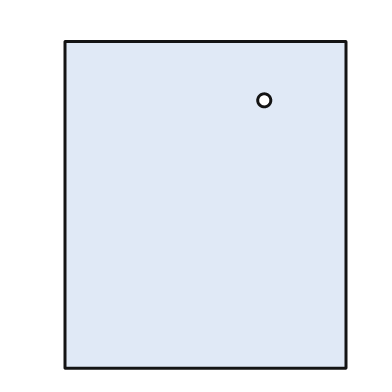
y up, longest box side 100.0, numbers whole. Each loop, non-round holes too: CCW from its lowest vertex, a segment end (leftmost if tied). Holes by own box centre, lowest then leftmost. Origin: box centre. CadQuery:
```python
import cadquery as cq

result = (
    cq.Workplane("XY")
    .moveTo(-43.0, -50.0)
    .lineTo(43.0, -50.0)
    .lineTo(43.0, 50.0)
    .lineTo(-43.0, 50.0)
    .close()
    .moveTo(18.0, 32.0)
    .circle(2.0)
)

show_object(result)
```